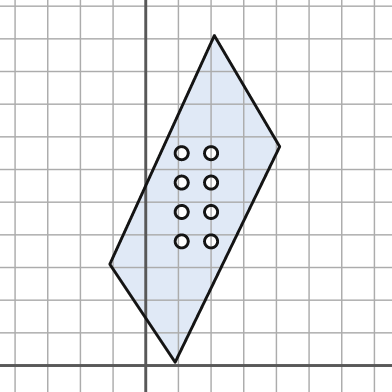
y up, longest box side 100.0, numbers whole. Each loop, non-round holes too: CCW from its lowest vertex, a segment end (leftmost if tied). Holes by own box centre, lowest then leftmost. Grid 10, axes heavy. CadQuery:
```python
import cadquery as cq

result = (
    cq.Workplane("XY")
    .moveTo(9.0, 1.0)
    .lineTo(41.0, 67.0)
    .lineTo(21.0, 101.0)
    .lineTo(-11.0, 31.0)
    .close()
    .moveTo(11.0, 38.0)
    .circle(2.0)
    .moveTo(20.0, 38.0)
    .circle(2.0)
    .moveTo(11.0, 47.0)
    .circle(2.0)
    .moveTo(20.0, 47.0)
    .circle(2.0)
    .moveTo(11.0, 56.0)
    .circle(2.0)
    .moveTo(20.0, 56.0)
    .circle(2.0)
    .moveTo(11.0, 65.0)
    .circle(2.0)
    .moveTo(20.0, 65.0)
    .circle(2.0)
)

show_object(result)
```